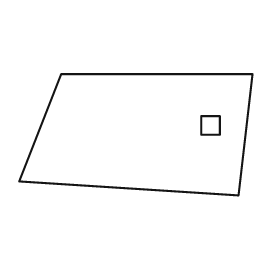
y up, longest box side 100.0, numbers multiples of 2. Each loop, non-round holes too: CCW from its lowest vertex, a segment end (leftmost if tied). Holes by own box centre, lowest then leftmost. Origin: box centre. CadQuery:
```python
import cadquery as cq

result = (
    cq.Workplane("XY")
    .moveTo(44.0, -26.0)
    .lineTo(50.0, 26.0)
    .lineTo(-32.0, 26.0)
    .lineTo(-50.0, -20.0)
    .close()
    .moveTo(28.0, 0.0)
    .lineTo(36.0, 0.0)
    .lineTo(36.0, 8.0)
    .lineTo(28.0, 8.0)
    .close()
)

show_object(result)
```